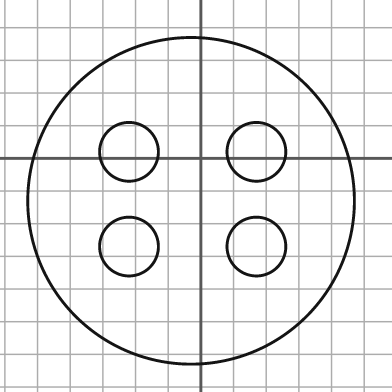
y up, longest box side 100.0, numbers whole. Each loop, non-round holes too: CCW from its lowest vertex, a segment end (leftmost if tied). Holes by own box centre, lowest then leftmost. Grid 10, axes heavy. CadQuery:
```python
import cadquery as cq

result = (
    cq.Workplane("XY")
    .moveTo(-3.0, -13.0)
    .circle(50.0)
    .moveTo(-22.0, -27.0)
    .circle(9.0)
    .moveTo(17.0, -27.0)
    .circle(9.0)
    .moveTo(-22.0, 2.0)
    .circle(9.0)
    .moveTo(17.0, 2.0)
    .circle(9.0)
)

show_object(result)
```